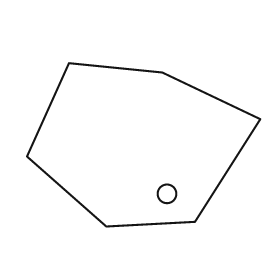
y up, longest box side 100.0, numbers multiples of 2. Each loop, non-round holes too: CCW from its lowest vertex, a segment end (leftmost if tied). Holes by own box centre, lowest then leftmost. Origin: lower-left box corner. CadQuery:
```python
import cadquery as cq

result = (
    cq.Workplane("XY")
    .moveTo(34.0, 0.0)
    .lineTo(72.0, 2.0)
    .lineTo(100.0, 46.0)
    .lineTo(58.0, 66.0)
    .lineTo(18.0, 70.0)
    .lineTo(0.0, 30.0)
    .close()
    .moveTo(60.0, 14.0)
    .circle(4.0)
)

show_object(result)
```